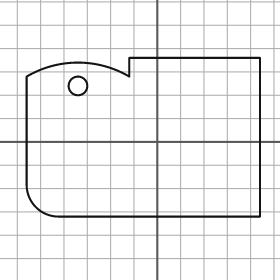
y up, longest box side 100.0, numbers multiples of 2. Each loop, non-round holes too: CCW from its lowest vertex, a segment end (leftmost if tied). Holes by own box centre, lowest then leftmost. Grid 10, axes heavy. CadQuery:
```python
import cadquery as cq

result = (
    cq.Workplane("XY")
    .moveTo(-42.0, -32.0)
    .lineTo(44.0, -32.0)
    .lineTo(44.0, 36.0)
    .lineTo(-12.0, 36.0)
    .lineTo(-12.0, 28.0)
    .threePointArc((-34.0, 34.0), (-56.0, 28.0))
    .lineTo(-56.0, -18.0)
    .threePointArc((-52.0, -28.0), (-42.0, -32.0))
    .close()
    .moveTo(-34.0, 24.0)
    .circle(4.0)
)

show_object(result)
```